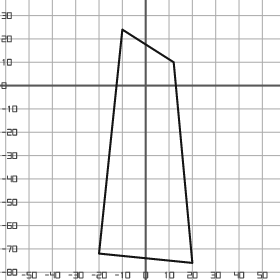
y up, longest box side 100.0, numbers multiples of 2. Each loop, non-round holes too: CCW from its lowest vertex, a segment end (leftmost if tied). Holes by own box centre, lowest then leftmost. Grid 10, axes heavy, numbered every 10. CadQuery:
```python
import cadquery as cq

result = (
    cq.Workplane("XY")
    .moveTo(20.0, -76.0)
    .lineTo(12.0, 10.0)
    .lineTo(-10.0, 24.0)
    .lineTo(-20.0, -72.0)
    .close()
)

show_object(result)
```